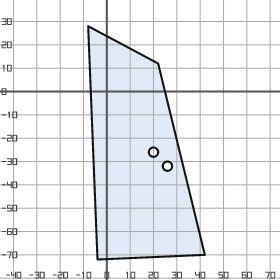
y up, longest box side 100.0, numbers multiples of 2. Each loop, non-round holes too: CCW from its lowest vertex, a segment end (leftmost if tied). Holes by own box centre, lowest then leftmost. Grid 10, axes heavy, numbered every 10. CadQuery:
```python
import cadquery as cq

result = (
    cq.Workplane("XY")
    .moveTo(-4.0, -72.0)
    .lineTo(42.0, -70.0)
    .lineTo(22.0, 12.0)
    .lineTo(-8.0, 28.0)
    .close()
    .moveTo(26.0, -32.0)
    .circle(2.0)
    .moveTo(20.0, -26.0)
    .circle(2.0)
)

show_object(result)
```